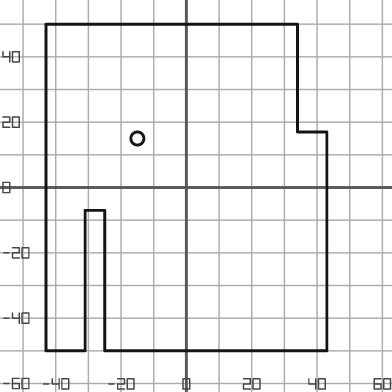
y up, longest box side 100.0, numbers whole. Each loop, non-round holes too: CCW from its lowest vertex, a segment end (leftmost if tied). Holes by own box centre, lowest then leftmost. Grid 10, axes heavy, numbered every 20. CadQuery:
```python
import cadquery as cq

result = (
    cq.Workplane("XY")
    .moveTo(-43.0, -50.0)
    .lineTo(-31.0, -50.0)
    .lineTo(-31.0, -7.0)
    .lineTo(-25.0, -7.0)
    .lineTo(-25.0, -50.0)
    .lineTo(43.0, -50.0)
    .lineTo(43.0, 17.0)
    .lineTo(34.0, 17.0)
    .lineTo(34.0, 50.0)
    .lineTo(-43.0, 50.0)
    .close()
    .moveTo(-15.0, 15.0)
    .circle(2.0)
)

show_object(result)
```